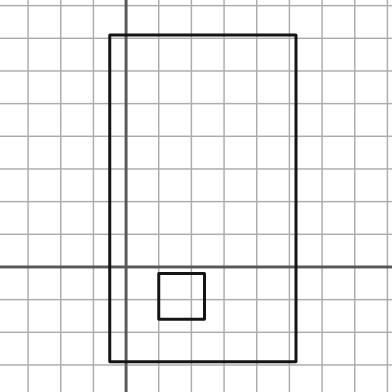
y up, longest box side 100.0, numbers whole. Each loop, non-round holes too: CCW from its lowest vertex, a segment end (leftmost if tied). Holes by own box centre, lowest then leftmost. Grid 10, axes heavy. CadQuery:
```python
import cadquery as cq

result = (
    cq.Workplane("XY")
    .moveTo(-5.0, -29.0)
    .lineTo(52.0, -29.0)
    .lineTo(52.0, 71.0)
    .lineTo(-5.0, 71.0)
    .close()
    .moveTo(10.0, -16.0)
    .lineTo(24.0, -16.0)
    .lineTo(24.0, -2.0)
    .lineTo(10.0, -2.0)
    .close()
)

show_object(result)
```